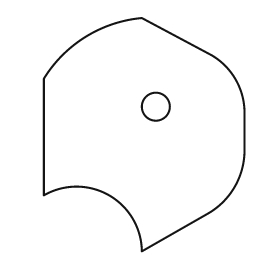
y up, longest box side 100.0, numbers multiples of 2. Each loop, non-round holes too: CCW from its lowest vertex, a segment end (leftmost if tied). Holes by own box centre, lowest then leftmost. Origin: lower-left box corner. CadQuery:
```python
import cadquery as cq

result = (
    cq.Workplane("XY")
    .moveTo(42.0, 0.0)
    .lineTo(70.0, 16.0)
    .threePointArc((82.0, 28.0), (86.0, 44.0))
    .lineTo(86.0, 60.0)
    .threePointArc((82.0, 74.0), (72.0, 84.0))
    .lineTo(42.0, 100.0)
    .threePointArc((18.0, 92.0), (0.0, 74.0))
    .lineTo(0.0, 24.0)
    .threePointArc((28.0, 24.0), (42.0, 0.0))
    .close()
    .moveTo(48.0, 62.0)
    .circle(6.0)
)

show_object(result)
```